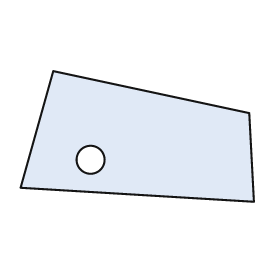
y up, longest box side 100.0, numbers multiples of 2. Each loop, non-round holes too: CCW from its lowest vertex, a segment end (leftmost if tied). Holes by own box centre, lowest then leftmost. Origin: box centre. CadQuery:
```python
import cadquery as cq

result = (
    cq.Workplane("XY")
    .moveTo(50.0, -28.0)
    .lineTo(48.0, 10.0)
    .lineTo(-36.0, 28.0)
    .lineTo(-50.0, -22.0)
    .close()
    .moveTo(-20.0, -10.0)
    .circle(6.0)
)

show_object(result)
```